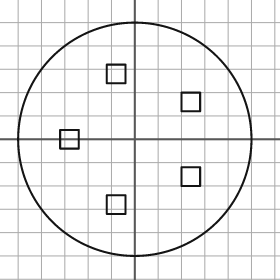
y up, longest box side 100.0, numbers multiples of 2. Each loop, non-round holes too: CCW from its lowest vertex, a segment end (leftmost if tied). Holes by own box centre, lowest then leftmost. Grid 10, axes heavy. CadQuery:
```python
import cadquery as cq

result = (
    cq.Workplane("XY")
    .moveTo(0.0, 0.0)
    .circle(50.0)
    .moveTo(-12.0, -32.0)
    .lineTo(-4.0, -32.0)
    .lineTo(-4.0, -24.0)
    .lineTo(-12.0, -24.0)
    .close()
    .moveTo(20.0, -20.0)
    .lineTo(28.0, -20.0)
    .lineTo(28.0, -12.0)
    .lineTo(20.0, -12.0)
    .close()
    .moveTo(-32.0, -4.0)
    .lineTo(-24.0, -4.0)
    .lineTo(-24.0, 4.0)
    .lineTo(-32.0, 4.0)
    .close()
    .moveTo(20.0, 12.0)
    .lineTo(28.0, 12.0)
    .lineTo(28.0, 20.0)
    .lineTo(20.0, 20.0)
    .close()
    .moveTo(-12.0, 24.0)
    .lineTo(-4.0, 24.0)
    .lineTo(-4.0, 32.0)
    .lineTo(-12.0, 32.0)
    .close()
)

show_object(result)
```